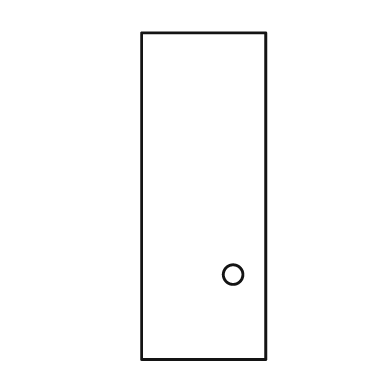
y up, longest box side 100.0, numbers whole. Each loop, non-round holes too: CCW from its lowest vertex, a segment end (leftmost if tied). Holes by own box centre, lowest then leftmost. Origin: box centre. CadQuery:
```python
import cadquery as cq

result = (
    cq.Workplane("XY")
    .moveTo(-19.0, -50.0)
    .lineTo(19.0, -50.0)
    .lineTo(19.0, 50.0)
    .lineTo(-19.0, 50.0)
    .close()
    .moveTo(9.0, -24.0)
    .circle(3.0)
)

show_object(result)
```